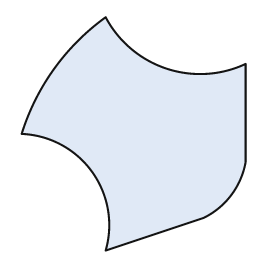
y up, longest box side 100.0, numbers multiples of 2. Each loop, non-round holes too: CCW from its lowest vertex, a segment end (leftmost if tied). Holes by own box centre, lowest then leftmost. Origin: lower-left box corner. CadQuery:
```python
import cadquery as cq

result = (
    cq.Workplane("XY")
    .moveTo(36.0, 0.0)
    .lineTo(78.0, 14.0)
    .threePointArc((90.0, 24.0), (96.0, 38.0))
    .lineTo(96.0, 80.0)
    .threePointArc((62.0, 78.0), (36.0, 100.0))
    .threePointArc((14.0, 78.0), (0.0, 50.0))
    .threePointArc((30.0, 34.0), (36.0, 0.0))
    .close()
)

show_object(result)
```